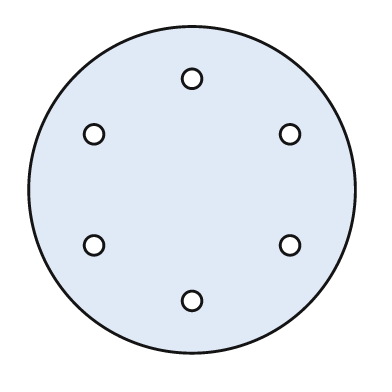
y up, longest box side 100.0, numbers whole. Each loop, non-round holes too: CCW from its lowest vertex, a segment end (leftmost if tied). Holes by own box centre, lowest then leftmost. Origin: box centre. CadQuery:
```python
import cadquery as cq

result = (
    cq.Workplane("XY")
    .moveTo(0.0, 0.0)
    .circle(50.0)
    .moveTo(0.0, -34.0)
    .circle(3.0)
    .moveTo(-30.0, -17.0)
    .circle(3.0)
    .moveTo(30.0, -17.0)
    .circle(3.0)
    .moveTo(-30.0, 17.0)
    .circle(3.0)
    .moveTo(30.0, 17.0)
    .circle(3.0)
    .moveTo(0.0, 34.0)
    .circle(3.0)
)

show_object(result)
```